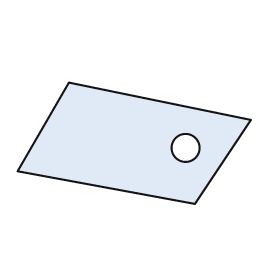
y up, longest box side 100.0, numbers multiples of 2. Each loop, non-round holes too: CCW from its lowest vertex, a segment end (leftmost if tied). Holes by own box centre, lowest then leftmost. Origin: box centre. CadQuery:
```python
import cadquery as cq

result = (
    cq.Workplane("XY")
    .moveTo(26.0, -26.0)
    .lineTo(50.0, 10.0)
    .lineTo(-28.0, 26.0)
    .lineTo(-50.0, -12.0)
    .close()
    .moveTo(22.0, -2.0)
    .circle(6.0)
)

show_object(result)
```